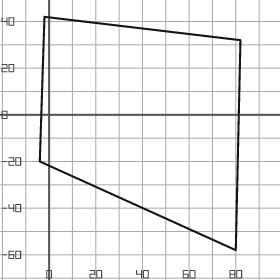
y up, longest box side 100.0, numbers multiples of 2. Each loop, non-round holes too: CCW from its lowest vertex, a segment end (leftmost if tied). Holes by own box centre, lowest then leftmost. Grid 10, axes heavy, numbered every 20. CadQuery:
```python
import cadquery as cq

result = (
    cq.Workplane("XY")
    .moveTo(80.0, -58.0)
    .lineTo(82.0, 32.0)
    .lineTo(-2.0, 42.0)
    .lineTo(-4.0, -20.0)
    .close()
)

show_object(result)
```